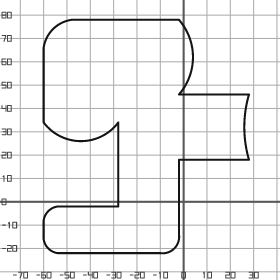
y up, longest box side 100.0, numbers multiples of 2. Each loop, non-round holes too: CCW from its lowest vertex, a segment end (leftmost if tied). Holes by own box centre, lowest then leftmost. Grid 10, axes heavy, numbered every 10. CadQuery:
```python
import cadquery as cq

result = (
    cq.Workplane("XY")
    .moveTo(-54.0, -22.0)
    .lineTo(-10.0, -22.0)
    .threePointArc((-4.0, -20.0), (-2.0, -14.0))
    .lineTo(-2.0, 18.0)
    .lineTo(28.0, 18.0)
    .threePointArc((26.0, 32.0), (28.0, 46.0))
    .lineTo(-2.0, 46.0)
    .threePointArc((4.0, 62.0), (-2.0, 78.0))
    .lineTo(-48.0, 78.0)
    .threePointArc((-56.0, 74.0), (-60.0, 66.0))
    .lineTo(-60.0, 34.0)
    .threePointArc((-44.0, 26.0), (-28.0, 34.0))
    .lineTo(-28.0, -2.0)
    .lineTo(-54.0, -2.0)
    .threePointArc((-58.0, -4.0), (-60.0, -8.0))
    .lineTo(-60.0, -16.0)
    .threePointArc((-58.0, -20.0), (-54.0, -22.0))
    .close()
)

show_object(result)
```